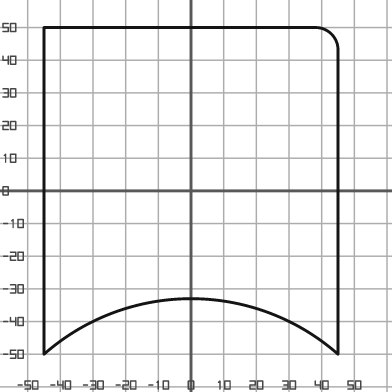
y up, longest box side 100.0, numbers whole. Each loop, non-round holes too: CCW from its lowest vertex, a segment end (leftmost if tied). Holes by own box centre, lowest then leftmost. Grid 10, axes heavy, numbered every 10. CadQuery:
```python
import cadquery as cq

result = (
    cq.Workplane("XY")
    .moveTo(-45.0, -50.0)
    .threePointArc((0.0, -33.0), (45.0, -50.0))
    .lineTo(45.0, 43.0)
    .threePointArc((43.0, 48.0), (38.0, 50.0))
    .lineTo(-45.0, 50.0)
    .close()
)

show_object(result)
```